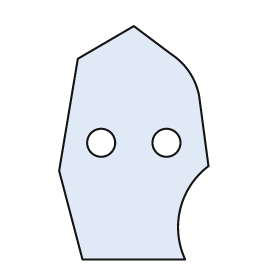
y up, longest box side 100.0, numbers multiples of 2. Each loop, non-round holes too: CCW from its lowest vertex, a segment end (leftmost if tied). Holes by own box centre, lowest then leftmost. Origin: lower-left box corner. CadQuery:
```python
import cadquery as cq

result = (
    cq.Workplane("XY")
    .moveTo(10.0, 0.0)
    .lineTo(54.0, 0.0)
    .threePointArc((52.0, 22.0), (64.0, 40.0))
    .lineTo(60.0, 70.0)
    .threePointArc((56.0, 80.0), (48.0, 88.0))
    .lineTo(32.0, 100.0)
    .lineTo(8.0, 86.0)
    .lineTo(0.0, 38.0)
    .close()
    .moveTo(18.0, 50.0)
    .circle(6.0)
    .moveTo(46.0, 50.0)
    .circle(6.0)
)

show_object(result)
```